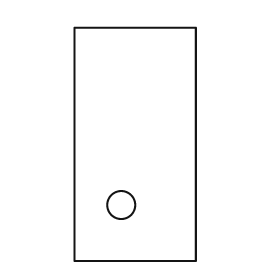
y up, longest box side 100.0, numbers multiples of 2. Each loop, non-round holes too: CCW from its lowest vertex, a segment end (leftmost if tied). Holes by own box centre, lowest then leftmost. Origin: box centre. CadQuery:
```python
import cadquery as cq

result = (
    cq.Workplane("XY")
    .moveTo(-26.0, -50.0)
    .lineTo(26.0, -50.0)
    .lineTo(26.0, 50.0)
    .lineTo(-26.0, 50.0)
    .close()
    .moveTo(-6.0, -26.0)
    .circle(6.0)
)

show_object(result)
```